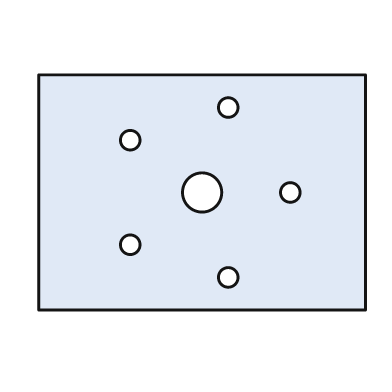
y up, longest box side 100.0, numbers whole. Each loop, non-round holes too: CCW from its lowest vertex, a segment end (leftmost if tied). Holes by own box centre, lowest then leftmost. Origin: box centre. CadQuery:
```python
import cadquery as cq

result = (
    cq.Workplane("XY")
    .moveTo(-50.0, -36.0)
    .lineTo(50.0, -36.0)
    .lineTo(50.0, 36.0)
    .lineTo(-50.0, 36.0)
    .close()
    .moveTo(8.0, -26.0)
    .circle(3.0)
    .moveTo(-22.0, -16.0)
    .circle(3.0)
    .moveTo(0.0, 0.0)
    .circle(6.0)
    .moveTo(27.0, 0.0)
    .circle(3.0)
    .moveTo(-22.0, 16.0)
    .circle(3.0)
    .moveTo(8.0, 26.0)
    .circle(3.0)
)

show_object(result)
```